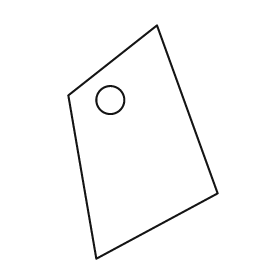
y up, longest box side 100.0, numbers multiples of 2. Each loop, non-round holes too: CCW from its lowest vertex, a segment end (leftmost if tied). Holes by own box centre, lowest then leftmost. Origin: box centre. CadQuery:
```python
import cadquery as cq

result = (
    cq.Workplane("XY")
    .moveTo(-20.0, -50.0)
    .lineTo(32.0, -22.0)
    .lineTo(6.0, 50.0)
    .lineTo(-32.0, 20.0)
    .close()
    .moveTo(-14.0, 18.0)
    .circle(6.0)
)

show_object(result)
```